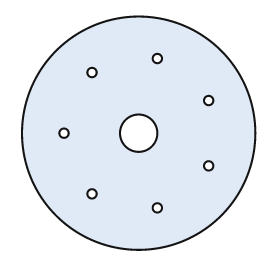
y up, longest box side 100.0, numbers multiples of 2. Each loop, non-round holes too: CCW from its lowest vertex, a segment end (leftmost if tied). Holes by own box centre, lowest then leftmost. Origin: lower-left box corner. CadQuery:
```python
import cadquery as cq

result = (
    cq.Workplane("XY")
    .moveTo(50.0, 50.0)
    .circle(50.0)
    .moveTo(58.0, 18.0)
    .circle(2.0)
    .moveTo(30.0, 24.0)
    .circle(2.0)
    .moveTo(80.0, 36.0)
    .circle(2.0)
    .moveTo(18.0, 50.0)
    .circle(2.0)
    .moveTo(50.0, 50.0)
    .circle(8.0)
    .moveTo(80.0, 64.0)
    .circle(2.0)
    .moveTo(30.0, 76.0)
    .circle(2.0)
    .moveTo(58.0, 82.0)
    .circle(2.0)
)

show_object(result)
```